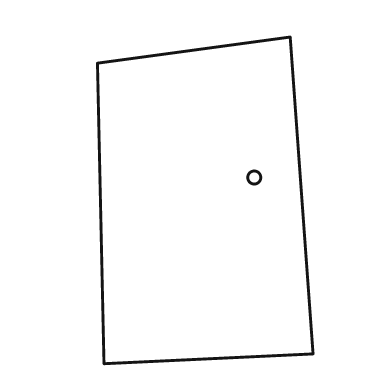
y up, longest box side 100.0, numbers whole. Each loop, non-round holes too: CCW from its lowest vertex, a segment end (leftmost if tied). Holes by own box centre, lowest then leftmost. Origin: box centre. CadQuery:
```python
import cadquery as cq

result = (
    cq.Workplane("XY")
    .moveTo(-31.0, -50.0)
    .lineTo(33.0, -47.0)
    .lineTo(26.0, 50.0)
    .lineTo(-33.0, 42.0)
    .close()
    .moveTo(15.0, 7.0)
    .circle(2.0)
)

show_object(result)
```